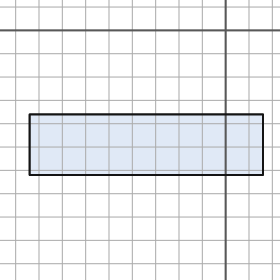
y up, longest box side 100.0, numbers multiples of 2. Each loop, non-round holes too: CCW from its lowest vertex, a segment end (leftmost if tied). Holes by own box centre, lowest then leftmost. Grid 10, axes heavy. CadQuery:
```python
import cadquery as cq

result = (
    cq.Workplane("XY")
    .moveTo(-84.0, -62.0)
    .lineTo(16.0, -62.0)
    .lineTo(16.0, -36.0)
    .lineTo(-84.0, -36.0)
    .close()
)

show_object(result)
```